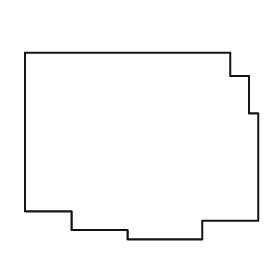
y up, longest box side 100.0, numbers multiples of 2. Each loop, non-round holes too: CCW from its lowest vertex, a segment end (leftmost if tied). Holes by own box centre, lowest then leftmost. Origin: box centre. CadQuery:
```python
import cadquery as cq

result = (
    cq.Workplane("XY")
    .moveTo(-6.0, -40.0)
    .lineTo(26.0, -40.0)
    .lineTo(26.0, -32.0)
    .lineTo(50.0, -32.0)
    .lineTo(50.0, 14.0)
    .lineTo(46.0, 14.0)
    .lineTo(46.0, 30.0)
    .lineTo(38.0, 30.0)
    .lineTo(38.0, 40.0)
    .lineTo(-50.0, 40.0)
    .lineTo(-50.0, -28.0)
    .lineTo(-30.0, -28.0)
    .lineTo(-30.0, -36.0)
    .lineTo(-6.0, -36.0)
    .close()
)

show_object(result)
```